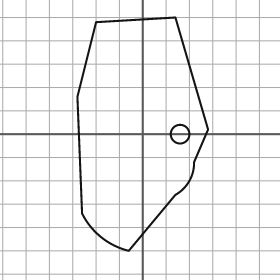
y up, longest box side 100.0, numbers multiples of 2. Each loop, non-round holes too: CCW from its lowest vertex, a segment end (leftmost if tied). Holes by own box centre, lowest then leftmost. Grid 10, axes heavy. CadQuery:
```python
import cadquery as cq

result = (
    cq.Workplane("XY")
    .moveTo(-6.0, -50.0)
    .lineTo(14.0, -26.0)
    .threePointArc((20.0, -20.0), (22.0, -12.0))
    .lineTo(28.0, 2.0)
    .lineTo(14.0, 50.0)
    .lineTo(-20.0, 48.0)
    .lineTo(-28.0, 16.0)
    .lineTo(-26.0, -34.0)
    .threePointArc((-18.0, -44.0), (-6.0, -50.0))
    .close()
    .moveTo(16.0, 0.0)
    .circle(4.0)
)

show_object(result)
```